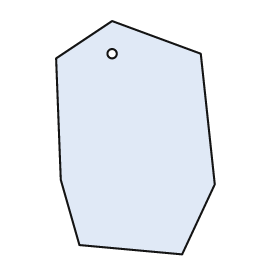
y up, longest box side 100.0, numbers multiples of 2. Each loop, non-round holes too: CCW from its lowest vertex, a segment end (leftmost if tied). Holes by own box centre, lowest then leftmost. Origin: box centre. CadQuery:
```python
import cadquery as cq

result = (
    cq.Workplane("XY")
    .moveTo(20.0, -50.0)
    .lineTo(34.0, -20.0)
    .lineTo(28.0, 36.0)
    .lineTo(-10.0, 50.0)
    .lineTo(-34.0, 34.0)
    .lineTo(-32.0, -18.0)
    .lineTo(-24.0, -46.0)
    .close()
    .moveTo(-10.0, 36.0)
    .circle(2.0)
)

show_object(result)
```